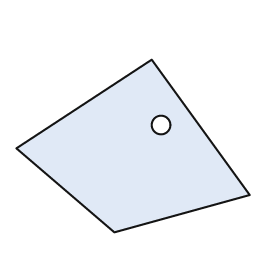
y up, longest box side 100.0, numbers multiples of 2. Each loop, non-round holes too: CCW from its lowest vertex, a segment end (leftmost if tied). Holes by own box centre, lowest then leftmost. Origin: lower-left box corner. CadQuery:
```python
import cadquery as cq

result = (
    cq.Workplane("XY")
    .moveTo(42.0, 0.0)
    .lineTo(100.0, 16.0)
    .lineTo(58.0, 74.0)
    .lineTo(0.0, 36.0)
    .close()
    .moveTo(62.0, 46.0)
    .circle(4.0)
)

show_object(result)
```